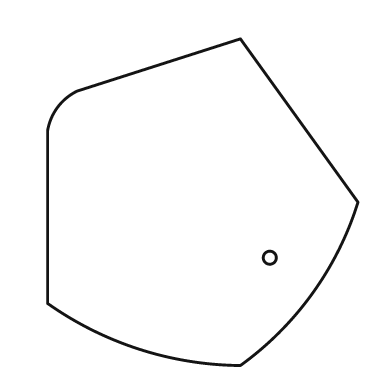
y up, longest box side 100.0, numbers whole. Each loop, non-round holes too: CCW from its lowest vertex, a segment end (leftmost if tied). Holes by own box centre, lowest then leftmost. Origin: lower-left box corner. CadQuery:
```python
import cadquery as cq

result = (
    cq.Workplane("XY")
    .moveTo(59.0, 0.0)
    .threePointArc((81.0, 22.0), (95.0, 50.0))
    .lineTo(59.0, 100.0)
    .lineTo(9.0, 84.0)
    .threePointArc((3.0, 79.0), (0.0, 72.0))
    .lineTo(0.0, 19.0)
    .threePointArc((28.0, 5.0), (59.0, 0.0))
    .close()
    .moveTo(68.0, 33.0)
    .circle(2.0)
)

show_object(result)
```